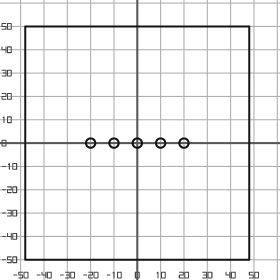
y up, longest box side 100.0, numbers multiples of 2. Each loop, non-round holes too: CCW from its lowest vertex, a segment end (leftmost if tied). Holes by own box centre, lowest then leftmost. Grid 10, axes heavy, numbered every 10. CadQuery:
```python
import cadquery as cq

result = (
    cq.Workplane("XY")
    .moveTo(-48.0, -50.0)
    .lineTo(48.0, -50.0)
    .lineTo(48.0, 50.0)
    .lineTo(-48.0, 50.0)
    .close()
    .moveTo(-20.0, 0.0)
    .circle(2.0)
    .moveTo(-10.0, 0.0)
    .circle(2.0)
    .moveTo(0.0, 0.0)
    .circle(2.0)
    .moveTo(10.0, 0.0)
    .circle(2.0)
    .moveTo(20.0, 0.0)
    .circle(2.0)
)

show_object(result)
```